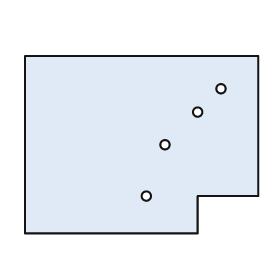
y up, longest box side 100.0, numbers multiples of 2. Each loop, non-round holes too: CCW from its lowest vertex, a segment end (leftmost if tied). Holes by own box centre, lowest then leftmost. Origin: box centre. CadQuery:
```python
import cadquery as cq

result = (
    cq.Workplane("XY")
    .moveTo(-50.0, -38.0)
    .lineTo(24.0, -38.0)
    .lineTo(24.0, -22.0)
    .lineTo(50.0, -22.0)
    .lineTo(50.0, 38.0)
    .lineTo(-50.0, 38.0)
    .close()
    .moveTo(2.0, -22.0)
    .circle(2.0)
    .moveTo(10.0, 0.0)
    .circle(2.0)
    .moveTo(24.0, 14.0)
    .circle(2.0)
    .moveTo(34.0, 24.0)
    .circle(2.0)
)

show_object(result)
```